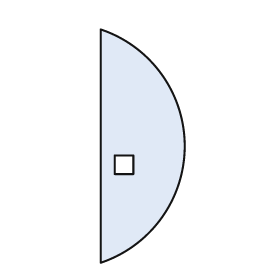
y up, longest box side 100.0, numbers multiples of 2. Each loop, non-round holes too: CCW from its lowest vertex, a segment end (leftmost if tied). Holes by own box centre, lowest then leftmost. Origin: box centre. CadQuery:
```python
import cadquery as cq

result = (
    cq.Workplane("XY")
    .moveTo(-18.0, -50.0)
    .threePointArc((18.0, 0.0), (-18.0, 50.0))
    .close()
    .moveTo(-12.0, -12.0)
    .lineTo(-4.0, -12.0)
    .lineTo(-4.0, -4.0)
    .lineTo(-12.0, -4.0)
    .close()
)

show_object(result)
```